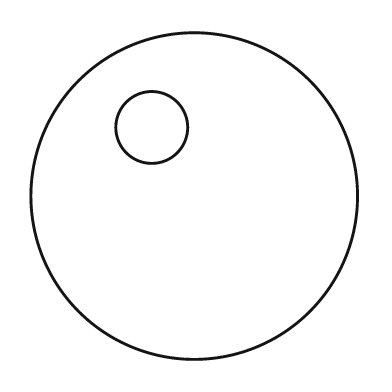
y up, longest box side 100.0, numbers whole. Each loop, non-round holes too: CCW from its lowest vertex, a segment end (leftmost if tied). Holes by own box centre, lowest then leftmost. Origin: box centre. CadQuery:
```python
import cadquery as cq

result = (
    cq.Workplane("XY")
    .moveTo(0.0, 0.0)
    .circle(50.0)
    .moveTo(-13.0, 21.0)
    .circle(11.0)
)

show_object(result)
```